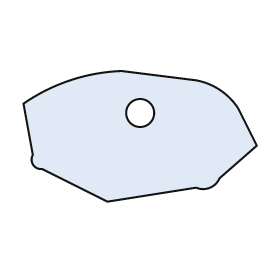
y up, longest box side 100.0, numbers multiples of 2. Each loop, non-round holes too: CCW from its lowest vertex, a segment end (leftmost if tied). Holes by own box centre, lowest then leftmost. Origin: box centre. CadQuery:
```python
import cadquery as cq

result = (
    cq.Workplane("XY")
    .moveTo(-14.0, -28.0)
    .lineTo(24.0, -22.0)
    .threePointArc((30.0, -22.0), (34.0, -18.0))
    .lineTo(50.0, -4.0)
    .lineTo(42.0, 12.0)
    .threePointArc((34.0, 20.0), (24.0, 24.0))
    .lineTo(-8.0, 28.0)
    .threePointArc((-30.0, 24.0), (-50.0, 14.0))
    .lineTo(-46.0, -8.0)
    .threePointArc((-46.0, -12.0), (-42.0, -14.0))
    .close()
    .moveTo(0.0, 10.0)
    .circle(6.0)
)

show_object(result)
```